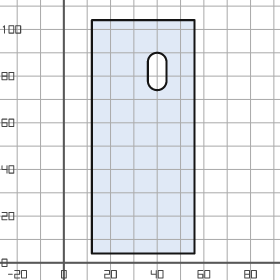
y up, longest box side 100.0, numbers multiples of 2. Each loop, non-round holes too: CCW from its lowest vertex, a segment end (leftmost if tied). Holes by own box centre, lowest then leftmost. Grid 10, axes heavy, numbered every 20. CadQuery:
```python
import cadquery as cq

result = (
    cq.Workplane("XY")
    .moveTo(12.0, 4.0)
    .lineTo(56.0, 4.0)
    .lineTo(56.0, 104.0)
    .lineTo(12.0, 104.0)
    .close()
    .moveTo(36.0, 78.0)
    .threePointArc((40.0, 74.0), (44.0, 78.0))
    .lineTo(44.0, 86.0)
    .threePointArc((40.0, 90.0), (36.0, 86.0))
    .close()
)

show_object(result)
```